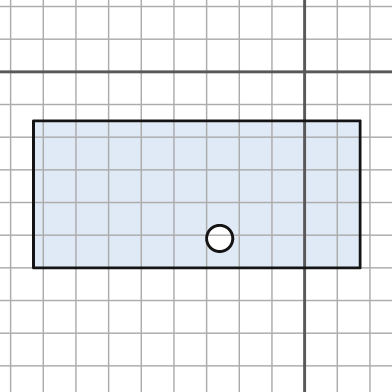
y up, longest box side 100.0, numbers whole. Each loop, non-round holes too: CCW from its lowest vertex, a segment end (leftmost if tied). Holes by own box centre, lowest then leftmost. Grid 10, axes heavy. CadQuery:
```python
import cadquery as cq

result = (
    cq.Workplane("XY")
    .moveTo(-83.0, -60.0)
    .lineTo(17.0, -60.0)
    .lineTo(17.0, -15.0)
    .lineTo(-83.0, -15.0)
    .close()
    .moveTo(-26.0, -51.0)
    .circle(4.0)
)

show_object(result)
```